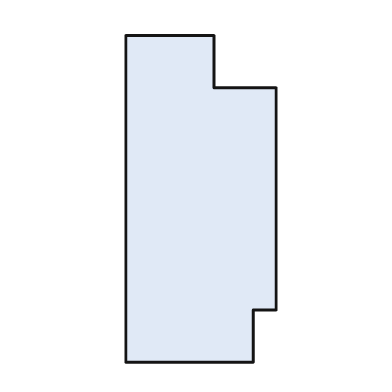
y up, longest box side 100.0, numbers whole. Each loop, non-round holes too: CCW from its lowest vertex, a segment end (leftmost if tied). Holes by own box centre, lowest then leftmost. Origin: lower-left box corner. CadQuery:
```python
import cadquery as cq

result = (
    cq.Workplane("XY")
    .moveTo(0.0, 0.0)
    .lineTo(39.0, 0.0)
    .lineTo(39.0, 16.0)
    .lineTo(46.0, 16.0)
    .lineTo(46.0, 84.0)
    .lineTo(27.0, 84.0)
    .lineTo(27.0, 100.0)
    .lineTo(0.0, 100.0)
    .close()
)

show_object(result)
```